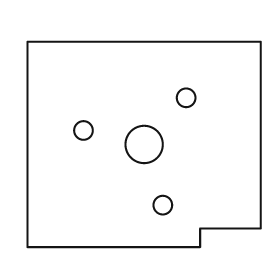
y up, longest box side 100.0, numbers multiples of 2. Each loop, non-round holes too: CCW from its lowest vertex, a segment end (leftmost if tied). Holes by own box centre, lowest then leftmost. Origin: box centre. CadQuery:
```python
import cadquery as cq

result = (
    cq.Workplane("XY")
    .moveTo(-50.0, -44.0)
    .lineTo(24.0, -44.0)
    .lineTo(24.0, -36.0)
    .lineTo(50.0, -36.0)
    .lineTo(50.0, 44.0)
    .lineTo(-50.0, 44.0)
    .close()
    .moveTo(8.0, -26.0)
    .circle(4.0)
    .moveTo(0.0, 0.0)
    .circle(8.0)
    .moveTo(-26.0, 6.0)
    .circle(4.0)
    .moveTo(18.0, 20.0)
    .circle(4.0)
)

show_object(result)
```